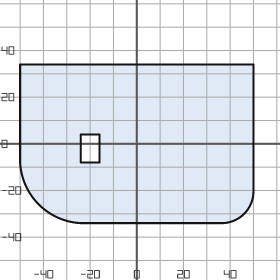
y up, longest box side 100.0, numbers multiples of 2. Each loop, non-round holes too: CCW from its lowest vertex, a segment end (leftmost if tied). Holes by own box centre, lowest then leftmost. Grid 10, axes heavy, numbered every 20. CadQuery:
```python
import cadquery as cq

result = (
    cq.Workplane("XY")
    .moveTo(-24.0, -34.0)
    .lineTo(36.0, -34.0)
    .threePointArc((46.0, -30.0), (50.0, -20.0))
    .lineTo(50.0, 34.0)
    .lineTo(-50.0, 34.0)
    .lineTo(-50.0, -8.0)
    .threePointArc((-42.0, -26.0), (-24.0, -34.0))
    .close()
    .moveTo(-24.0, -8.0)
    .lineTo(-16.0, -8.0)
    .lineTo(-16.0, 4.0)
    .lineTo(-24.0, 4.0)
    .close()
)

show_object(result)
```